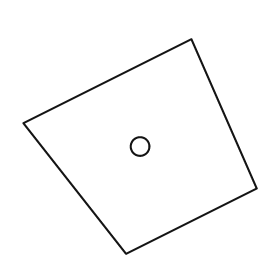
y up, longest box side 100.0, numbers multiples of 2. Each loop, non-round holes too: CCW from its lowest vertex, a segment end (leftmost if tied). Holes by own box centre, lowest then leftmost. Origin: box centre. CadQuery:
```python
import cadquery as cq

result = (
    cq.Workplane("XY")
    .moveTo(-6.0, -46.0)
    .lineTo(50.0, -18.0)
    .lineTo(22.0, 46.0)
    .lineTo(-50.0, 10.0)
    .close()
    .moveTo(0.0, 0.0)
    .circle(4.0)
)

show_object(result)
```